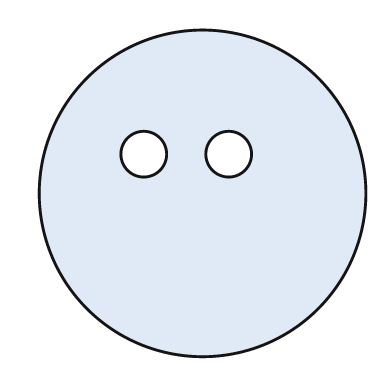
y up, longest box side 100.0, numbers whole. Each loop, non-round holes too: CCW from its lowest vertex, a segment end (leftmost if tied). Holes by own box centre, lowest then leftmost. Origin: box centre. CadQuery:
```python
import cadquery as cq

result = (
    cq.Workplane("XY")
    .moveTo(0.0, 0.0)
    .circle(50.0)
    .moveTo(-18.0, 12.0)
    .circle(7.0)
    .moveTo(8.0, 12.0)
    .circle(7.0)
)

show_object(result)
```